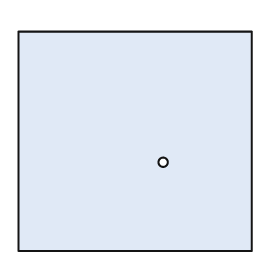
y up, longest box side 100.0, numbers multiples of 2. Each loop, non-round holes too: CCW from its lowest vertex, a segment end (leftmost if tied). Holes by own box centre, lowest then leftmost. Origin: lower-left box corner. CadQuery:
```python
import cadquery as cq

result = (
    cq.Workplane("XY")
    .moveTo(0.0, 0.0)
    .lineTo(100.0, 0.0)
    .lineTo(100.0, 94.0)
    .lineTo(0.0, 94.0)
    .close()
    .moveTo(62.0, 38.0)
    .circle(2.0)
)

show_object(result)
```